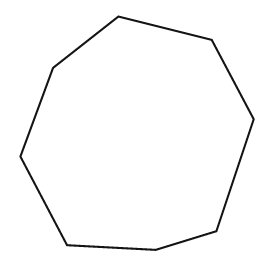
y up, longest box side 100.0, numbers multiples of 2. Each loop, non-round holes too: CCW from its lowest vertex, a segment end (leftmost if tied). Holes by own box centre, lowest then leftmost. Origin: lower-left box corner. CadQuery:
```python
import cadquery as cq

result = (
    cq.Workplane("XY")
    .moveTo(58.0, 0.0)
    .lineTo(84.0, 8.0)
    .lineTo(100.0, 56.0)
    .lineTo(82.0, 90.0)
    .lineTo(42.0, 100.0)
    .lineTo(14.0, 78.0)
    .lineTo(0.0, 40.0)
    .lineTo(20.0, 2.0)
    .close()
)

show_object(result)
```